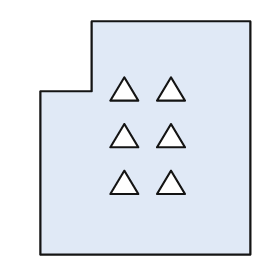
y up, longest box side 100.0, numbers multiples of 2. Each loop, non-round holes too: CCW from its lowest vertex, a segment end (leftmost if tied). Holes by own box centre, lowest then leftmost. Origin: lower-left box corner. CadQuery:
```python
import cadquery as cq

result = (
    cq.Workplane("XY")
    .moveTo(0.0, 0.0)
    .lineTo(90.0, 0.0)
    .lineTo(90.0, 100.0)
    .lineTo(22.0, 100.0)
    .lineTo(22.0, 70.0)
    .lineTo(0.0, 70.0)
    .close()
    .moveTo(30.0, 26.0)
    .lineTo(42.0, 26.0)
    .lineTo(36.0, 36.0)
    .close()
    .moveTo(50.0, 26.0)
    .lineTo(62.0, 26.0)
    .lineTo(56.0, 36.0)
    .close()
    .moveTo(30.0, 46.0)
    .lineTo(42.0, 46.0)
    .lineTo(36.0, 56.0)
    .close()
    .moveTo(50.0, 46.0)
    .lineTo(62.0, 46.0)
    .lineTo(56.0, 56.0)
    .close()
    .moveTo(30.0, 66.0)
    .lineTo(42.0, 66.0)
    .lineTo(36.0, 76.0)
    .close()
    .moveTo(50.0, 66.0)
    .lineTo(62.0, 66.0)
    .lineTo(56.0, 76.0)
    .close()
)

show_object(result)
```